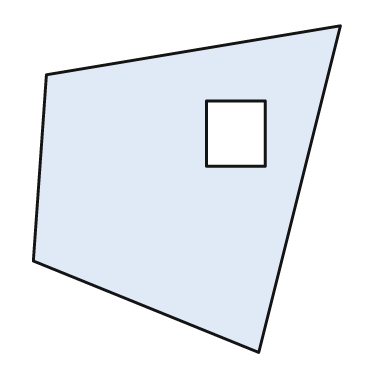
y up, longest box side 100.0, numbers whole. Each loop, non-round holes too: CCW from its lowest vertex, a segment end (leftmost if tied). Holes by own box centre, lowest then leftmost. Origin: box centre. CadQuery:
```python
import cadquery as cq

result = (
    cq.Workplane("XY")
    .moveTo(22.0, -50.0)
    .lineTo(47.0, 50.0)
    .lineTo(-43.0, 35.0)
    .lineTo(-47.0, -22.0)
    .close()
    .moveTo(6.0, 7.0)
    .lineTo(24.0, 7.0)
    .lineTo(24.0, 27.0)
    .lineTo(6.0, 27.0)
    .close()
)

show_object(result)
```